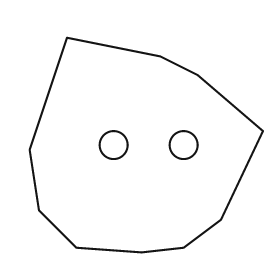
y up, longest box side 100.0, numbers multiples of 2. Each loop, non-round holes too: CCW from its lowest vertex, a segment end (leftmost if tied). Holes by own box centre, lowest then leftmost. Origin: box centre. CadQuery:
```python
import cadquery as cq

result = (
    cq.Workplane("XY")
    .moveTo(-2.0, -46.0)
    .lineTo(16.0, -44.0)
    .lineTo(32.0, -32.0)
    .lineTo(50.0, 6.0)
    .lineTo(22.0, 30.0)
    .lineTo(6.0, 38.0)
    .lineTo(-34.0, 46.0)
    .lineTo(-50.0, -2.0)
    .lineTo(-46.0, -28.0)
    .lineTo(-30.0, -44.0)
    .close()
    .moveTo(-14.0, 0.0)
    .circle(6.0)
    .moveTo(16.0, 0.0)
    .circle(6.0)
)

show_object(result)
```